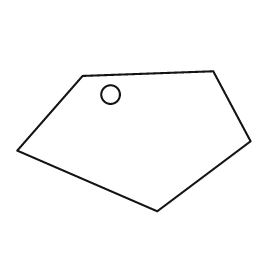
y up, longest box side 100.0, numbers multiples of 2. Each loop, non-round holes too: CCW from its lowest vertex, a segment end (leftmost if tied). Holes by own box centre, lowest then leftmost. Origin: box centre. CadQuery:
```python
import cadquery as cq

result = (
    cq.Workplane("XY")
    .moveTo(10.0, -30.0)
    .lineTo(50.0, 0.0)
    .lineTo(34.0, 30.0)
    .lineTo(-22.0, 28.0)
    .lineTo(-50.0, -4.0)
    .close()
    .moveTo(-10.0, 20.0)
    .circle(4.0)
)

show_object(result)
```